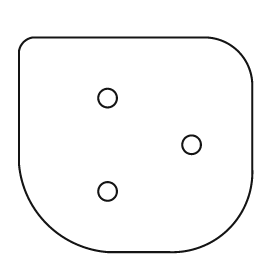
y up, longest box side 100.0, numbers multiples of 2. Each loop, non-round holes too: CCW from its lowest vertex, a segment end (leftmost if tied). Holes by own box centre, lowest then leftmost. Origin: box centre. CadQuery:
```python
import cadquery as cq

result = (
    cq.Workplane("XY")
    .moveTo(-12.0, -46.0)
    .lineTo(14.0, -46.0)
    .threePointArc((40.0, -36.0), (50.0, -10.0))
    .lineTo(50.0, 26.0)
    .threePointArc((44.0, 40.0), (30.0, 46.0))
    .lineTo(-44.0, 46.0)
    .threePointArc((-48.0, 44.0), (-50.0, 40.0))
    .lineTo(-50.0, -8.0)
    .threePointArc((-38.0, -34.0), (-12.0, -46.0))
    .close()
    .moveTo(-12.0, -20.0)
    .circle(4.0)
    .moveTo(24.0, 0.0)
    .circle(4.0)
    .moveTo(-12.0, 20.0)
    .circle(4.0)
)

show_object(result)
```